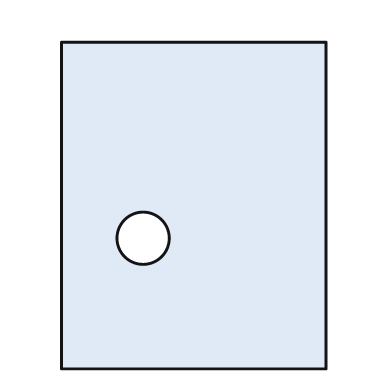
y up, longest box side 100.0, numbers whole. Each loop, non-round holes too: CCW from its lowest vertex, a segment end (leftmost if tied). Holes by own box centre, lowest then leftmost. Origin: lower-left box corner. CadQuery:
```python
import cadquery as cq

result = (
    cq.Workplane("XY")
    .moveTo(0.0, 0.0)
    .lineTo(81.0, 0.0)
    .lineTo(81.0, 100.0)
    .lineTo(0.0, 100.0)
    .close()
    .moveTo(25.0, 40.0)
    .circle(8.0)
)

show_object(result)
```